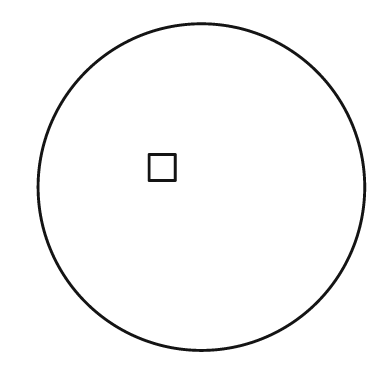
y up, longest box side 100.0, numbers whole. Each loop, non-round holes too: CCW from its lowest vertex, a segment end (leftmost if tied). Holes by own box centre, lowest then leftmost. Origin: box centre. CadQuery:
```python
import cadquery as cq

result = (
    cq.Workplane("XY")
    .moveTo(0.0, 0.0)
    .circle(50.0)
    .moveTo(-16.0, 2.0)
    .lineTo(-8.0, 2.0)
    .lineTo(-8.0, 10.0)
    .lineTo(-16.0, 10.0)
    .close()
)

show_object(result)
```